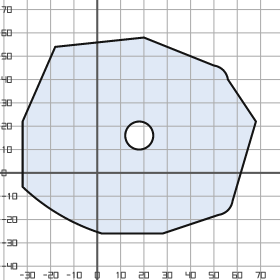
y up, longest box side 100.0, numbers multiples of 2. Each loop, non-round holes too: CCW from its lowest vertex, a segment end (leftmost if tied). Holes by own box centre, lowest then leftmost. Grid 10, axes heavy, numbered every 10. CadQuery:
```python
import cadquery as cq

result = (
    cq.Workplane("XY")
    .moveTo(2.0, -26.0)
    .lineTo(28.0, -26.0)
    .lineTo(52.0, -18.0)
    .threePointArc((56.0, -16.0), (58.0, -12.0))
    .lineTo(68.0, 22.0)
    .lineTo(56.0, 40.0)
    .threePointArc((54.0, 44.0), (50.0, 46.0))
    .lineTo(20.0, 58.0)
    .lineTo(-18.0, 54.0)
    .lineTo(-32.0, 22.0)
    .lineTo(-32.0, -6.0)
    .threePointArc((-16.0, -18.0), (2.0, -26.0))
    .close()
    .moveTo(18.0, 16.0)
    .circle(6.0)
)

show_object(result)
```